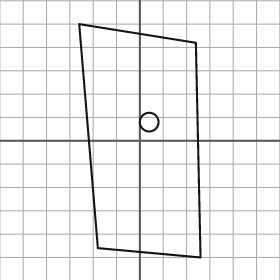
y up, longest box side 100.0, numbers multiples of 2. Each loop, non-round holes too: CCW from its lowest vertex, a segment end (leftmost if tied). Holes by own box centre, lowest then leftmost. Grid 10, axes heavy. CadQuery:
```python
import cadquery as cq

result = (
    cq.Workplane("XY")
    .moveTo(26.0, -50.0)
    .lineTo(24.0, 42.0)
    .lineTo(-26.0, 50.0)
    .lineTo(-18.0, -46.0)
    .close()
    .moveTo(4.0, 8.0)
    .circle(4.0)
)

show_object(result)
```